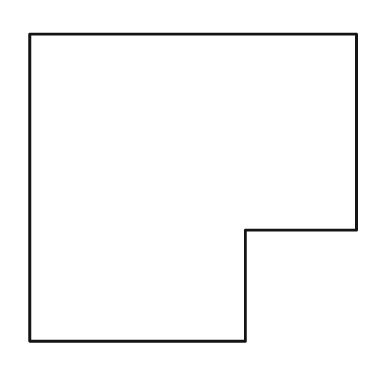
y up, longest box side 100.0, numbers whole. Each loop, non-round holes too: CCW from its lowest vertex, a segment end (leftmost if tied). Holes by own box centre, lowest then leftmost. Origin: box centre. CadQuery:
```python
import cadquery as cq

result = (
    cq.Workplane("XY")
    .moveTo(-50.0, -47.0)
    .lineTo(16.0, -47.0)
    .lineTo(16.0, -13.0)
    .lineTo(50.0, -13.0)
    .lineTo(50.0, 47.0)
    .lineTo(-50.0, 47.0)
    .close()
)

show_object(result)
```